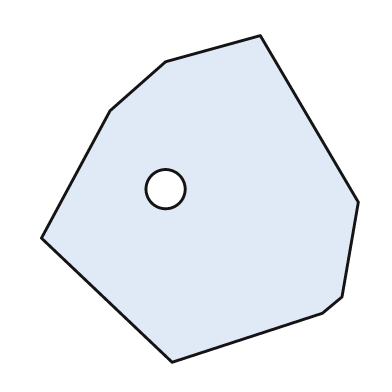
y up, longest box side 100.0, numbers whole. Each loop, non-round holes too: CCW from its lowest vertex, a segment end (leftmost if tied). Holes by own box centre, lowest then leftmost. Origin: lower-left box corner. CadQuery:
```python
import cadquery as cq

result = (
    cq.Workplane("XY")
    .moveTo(40.0, 0.0)
    .lineTo(86.0, 15.0)
    .lineTo(92.0, 20.0)
    .lineTo(97.0, 49.0)
    .lineTo(67.0, 100.0)
    .lineTo(38.0, 92.0)
    .lineTo(21.0, 77.0)
    .lineTo(0.0, 38.0)
    .close()
    .moveTo(38.0, 53.0)
    .circle(6.0)
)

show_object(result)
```